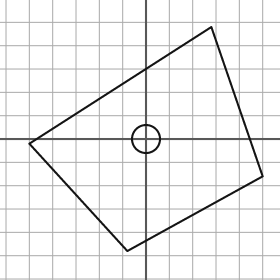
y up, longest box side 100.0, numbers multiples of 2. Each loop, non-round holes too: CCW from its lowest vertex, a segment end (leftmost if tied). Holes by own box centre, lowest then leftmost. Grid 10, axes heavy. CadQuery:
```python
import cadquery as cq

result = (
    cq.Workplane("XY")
    .moveTo(-8.0, -48.0)
    .lineTo(50.0, -16.0)
    .lineTo(28.0, 48.0)
    .lineTo(-50.0, -2.0)
    .close()
    .moveTo(0.0, 0.0)
    .circle(6.0)
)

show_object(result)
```